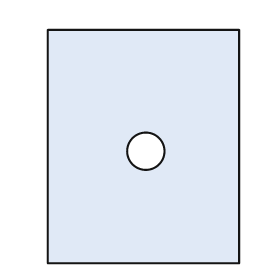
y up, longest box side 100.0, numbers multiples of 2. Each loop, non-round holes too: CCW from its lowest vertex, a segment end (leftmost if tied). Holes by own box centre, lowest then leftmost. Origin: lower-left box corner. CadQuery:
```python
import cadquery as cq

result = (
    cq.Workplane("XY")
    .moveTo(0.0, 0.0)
    .lineTo(82.0, 0.0)
    .lineTo(82.0, 100.0)
    .lineTo(0.0, 100.0)
    .close()
    .moveTo(42.0, 48.0)
    .circle(8.0)
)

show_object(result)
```